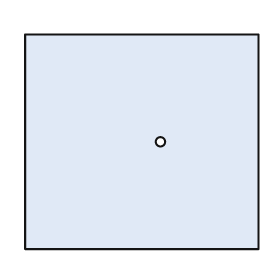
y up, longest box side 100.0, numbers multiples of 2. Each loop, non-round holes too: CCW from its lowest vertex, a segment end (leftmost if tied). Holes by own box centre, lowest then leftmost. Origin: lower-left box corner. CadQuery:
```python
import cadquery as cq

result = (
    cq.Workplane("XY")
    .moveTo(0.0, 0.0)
    .lineTo(100.0, 0.0)
    .lineTo(100.0, 92.0)
    .lineTo(0.0, 92.0)
    .close()
    .moveTo(58.0, 46.0)
    .circle(2.0)
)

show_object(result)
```